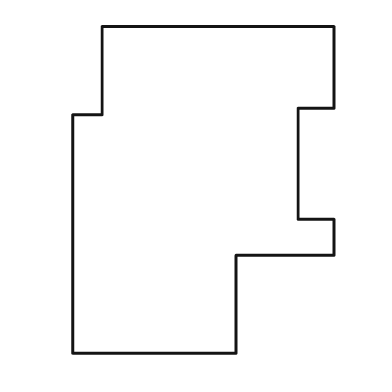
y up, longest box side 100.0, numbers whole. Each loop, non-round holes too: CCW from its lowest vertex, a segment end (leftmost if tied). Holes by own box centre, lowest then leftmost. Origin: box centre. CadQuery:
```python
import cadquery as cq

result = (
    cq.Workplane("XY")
    .moveTo(-40.0, -50.0)
    .lineTo(10.0, -50.0)
    .lineTo(10.0, -20.0)
    .lineTo(40.0, -20.0)
    .lineTo(40.0, -9.0)
    .lineTo(29.0, -9.0)
    .lineTo(29.0, 25.0)
    .lineTo(40.0, 25.0)
    .lineTo(40.0, 50.0)
    .lineTo(-31.0, 50.0)
    .lineTo(-31.0, 23.0)
    .lineTo(-40.0, 23.0)
    .close()
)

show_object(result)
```